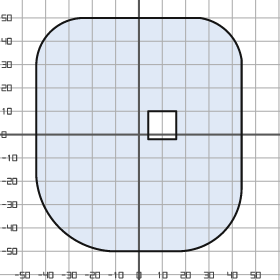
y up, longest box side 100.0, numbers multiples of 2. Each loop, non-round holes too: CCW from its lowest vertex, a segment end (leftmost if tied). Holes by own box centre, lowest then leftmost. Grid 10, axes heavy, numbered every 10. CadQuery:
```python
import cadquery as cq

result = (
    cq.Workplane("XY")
    .moveTo(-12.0, -50.0)
    .lineTo(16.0, -50.0)
    .threePointArc((36.0, -42.0), (44.0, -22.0))
    .lineTo(44.0, 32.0)
    .threePointArc((38.0, 44.0), (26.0, 50.0))
    .lineTo(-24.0, 50.0)
    .threePointArc((-38.0, 44.0), (-44.0, 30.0))
    .lineTo(-44.0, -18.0)
    .threePointArc((-34.0, -40.0), (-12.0, -50.0))
    .close()
    .moveTo(4.0, -2.0)
    .lineTo(16.0, -2.0)
    .lineTo(16.0, 10.0)
    .lineTo(4.0, 10.0)
    .close()
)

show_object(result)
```